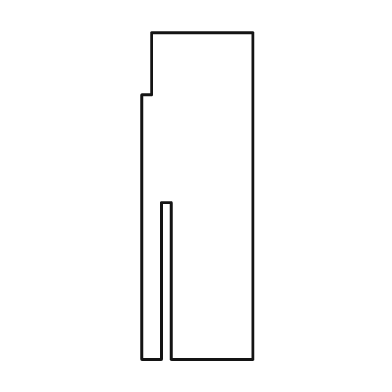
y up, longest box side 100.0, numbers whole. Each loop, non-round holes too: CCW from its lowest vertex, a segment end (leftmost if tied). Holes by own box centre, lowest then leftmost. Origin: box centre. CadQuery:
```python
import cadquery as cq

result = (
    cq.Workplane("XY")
    .moveTo(-17.0, -50.0)
    .lineTo(-11.0, -50.0)
    .lineTo(-11.0, -2.0)
    .lineTo(-8.0, -2.0)
    .lineTo(-8.0, -50.0)
    .lineTo(17.0, -50.0)
    .lineTo(17.0, 50.0)
    .lineTo(-14.0, 50.0)
    .lineTo(-14.0, 31.0)
    .lineTo(-17.0, 31.0)
    .close()
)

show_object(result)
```